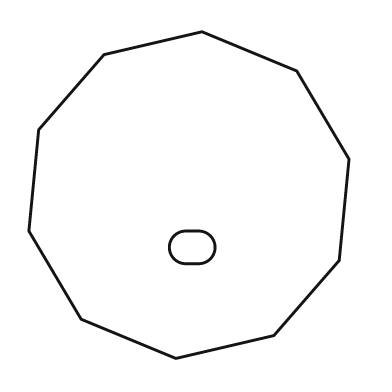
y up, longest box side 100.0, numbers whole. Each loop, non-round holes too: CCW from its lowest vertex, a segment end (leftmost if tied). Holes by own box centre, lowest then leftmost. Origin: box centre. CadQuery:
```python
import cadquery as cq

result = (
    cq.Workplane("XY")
    .moveTo(-4.0, -50.0)
    .lineTo(26.0, -43.0)
    .lineTo(46.0, -20.0)
    .lineTo(49.0, 11.0)
    .lineTo(33.0, 38.0)
    .lineTo(4.0, 50.0)
    .lineTo(-26.0, 43.0)
    .lineTo(-46.0, 20.0)
    .lineTo(-49.0, -11.0)
    .lineTo(-33.0, -38.0)
    .close()
    .moveTo(-1.0, -21.0)
    .lineTo(3.0, -21.0)
    .threePointArc((8.0, -16.0), (3.0, -11.0))
    .lineTo(-1.0, -11.0)
    .threePointArc((-6.0, -16.0), (-1.0, -21.0))
    .close()
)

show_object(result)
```